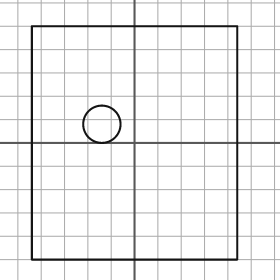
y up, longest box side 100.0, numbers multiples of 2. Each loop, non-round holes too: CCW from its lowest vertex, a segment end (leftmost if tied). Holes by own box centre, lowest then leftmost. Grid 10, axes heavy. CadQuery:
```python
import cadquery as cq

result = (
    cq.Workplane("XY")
    .moveTo(-44.0, -50.0)
    .lineTo(44.0, -50.0)
    .lineTo(44.0, 50.0)
    .lineTo(-44.0, 50.0)
    .close()
    .moveTo(-14.0, 8.0)
    .circle(8.0)
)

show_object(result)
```